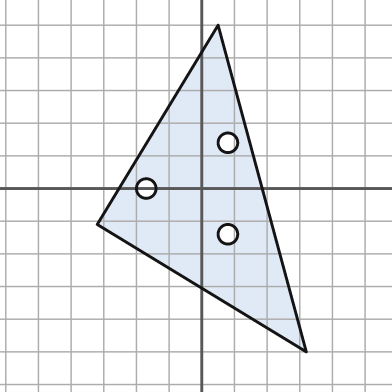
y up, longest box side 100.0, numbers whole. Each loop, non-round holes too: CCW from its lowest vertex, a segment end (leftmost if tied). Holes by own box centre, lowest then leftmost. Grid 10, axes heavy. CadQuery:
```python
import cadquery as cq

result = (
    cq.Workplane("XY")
    .moveTo(32.0, -50.0)
    .lineTo(5.0, 50.0)
    .lineTo(-32.0, -11.0)
    .close()
    .moveTo(8.0, -14.0)
    .circle(3.0)
    .moveTo(-17.0, 0.0)
    .circle(3.0)
    .moveTo(8.0, 14.0)
    .circle(3.0)
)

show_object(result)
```